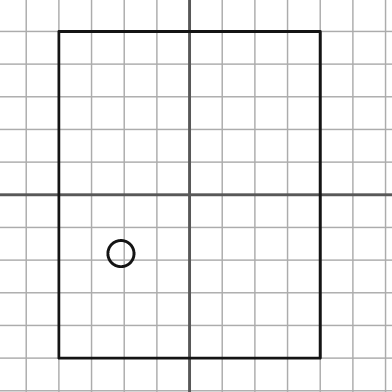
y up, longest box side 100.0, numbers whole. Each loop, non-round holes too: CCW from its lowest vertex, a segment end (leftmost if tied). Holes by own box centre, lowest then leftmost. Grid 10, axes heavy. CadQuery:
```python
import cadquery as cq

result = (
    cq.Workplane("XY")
    .moveTo(-40.0, -50.0)
    .lineTo(40.0, -50.0)
    .lineTo(40.0, 50.0)
    .lineTo(-40.0, 50.0)
    .close()
    .moveTo(-21.0, -18.0)
    .circle(4.0)
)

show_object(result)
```